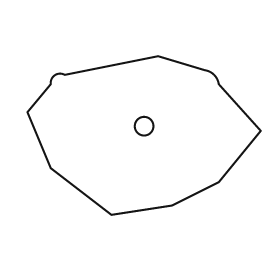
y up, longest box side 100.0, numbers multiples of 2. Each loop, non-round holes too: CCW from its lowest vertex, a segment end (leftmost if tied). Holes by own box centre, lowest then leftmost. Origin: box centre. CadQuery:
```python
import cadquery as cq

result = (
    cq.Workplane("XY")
    .moveTo(-14.0, -34.0)
    .lineTo(12.0, -30.0)
    .lineTo(32.0, -20.0)
    .lineTo(50.0, 2.0)
    .lineTo(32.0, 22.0)
    .threePointArc((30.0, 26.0), (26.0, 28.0))
    .lineTo(6.0, 34.0)
    .lineTo(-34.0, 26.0)
    .threePointArc((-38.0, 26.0), (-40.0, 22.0))
    .lineTo(-50.0, 10.0)
    .lineTo(-40.0, -14.0)
    .close()
    .moveTo(0.0, 4.0)
    .circle(4.0)
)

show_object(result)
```